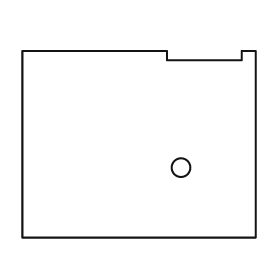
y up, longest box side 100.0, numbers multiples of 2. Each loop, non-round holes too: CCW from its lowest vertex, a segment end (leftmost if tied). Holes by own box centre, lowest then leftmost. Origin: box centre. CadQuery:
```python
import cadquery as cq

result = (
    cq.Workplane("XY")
    .moveTo(-50.0, -40.0)
    .lineTo(50.0, -40.0)
    .lineTo(50.0, 40.0)
    .lineTo(44.0, 40.0)
    .lineTo(44.0, 36.0)
    .lineTo(12.0, 36.0)
    .lineTo(12.0, 40.0)
    .lineTo(-50.0, 40.0)
    .close()
    .moveTo(18.0, -10.0)
    .circle(4.0)
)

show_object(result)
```